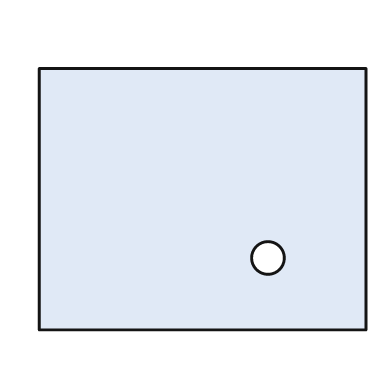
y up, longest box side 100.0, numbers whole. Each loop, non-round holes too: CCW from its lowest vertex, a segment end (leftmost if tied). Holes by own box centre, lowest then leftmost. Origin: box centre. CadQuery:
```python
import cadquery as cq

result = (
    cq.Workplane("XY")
    .moveTo(-50.0, -40.0)
    .lineTo(50.0, -40.0)
    .lineTo(50.0, 40.0)
    .lineTo(-50.0, 40.0)
    .close()
    .moveTo(20.0, -18.0)
    .circle(5.0)
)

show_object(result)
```